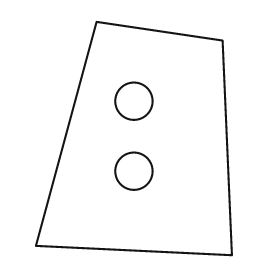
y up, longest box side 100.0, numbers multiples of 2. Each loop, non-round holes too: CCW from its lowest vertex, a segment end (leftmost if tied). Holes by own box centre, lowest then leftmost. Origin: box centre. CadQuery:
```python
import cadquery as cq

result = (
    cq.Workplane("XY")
    .moveTo(42.0, -50.0)
    .lineTo(38.0, 42.0)
    .lineTo(-16.0, 50.0)
    .lineTo(-42.0, -46.0)
    .close()
    .moveTo(0.0, -14.0)
    .circle(8.0)
    .moveTo(0.0, 16.0)
    .circle(8.0)
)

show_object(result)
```